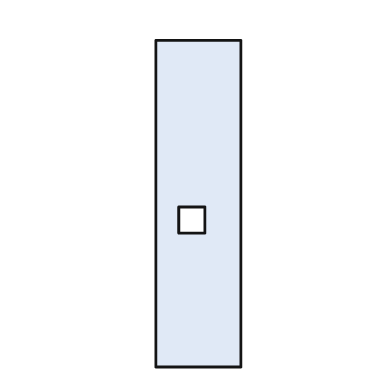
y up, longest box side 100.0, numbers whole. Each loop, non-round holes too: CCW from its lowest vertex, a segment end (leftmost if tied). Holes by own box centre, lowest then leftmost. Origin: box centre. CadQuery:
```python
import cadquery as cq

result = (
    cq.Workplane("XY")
    .moveTo(-13.0, -50.0)
    .lineTo(13.0, -50.0)
    .lineTo(13.0, 50.0)
    .lineTo(-13.0, 50.0)
    .close()
    .moveTo(-6.0, -9.0)
    .lineTo(2.0, -9.0)
    .lineTo(2.0, -1.0)
    .lineTo(-6.0, -1.0)
    .close()
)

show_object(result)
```